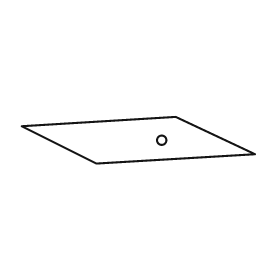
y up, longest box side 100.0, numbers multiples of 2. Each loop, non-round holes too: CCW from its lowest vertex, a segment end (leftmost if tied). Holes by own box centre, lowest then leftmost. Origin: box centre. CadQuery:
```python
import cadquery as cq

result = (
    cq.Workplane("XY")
    .moveTo(-18.0, -10.0)
    .lineTo(50.0, -6.0)
    .lineTo(16.0, 10.0)
    .lineTo(-50.0, 6.0)
    .close()
    .moveTo(10.0, 0.0)
    .circle(2.0)
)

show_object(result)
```